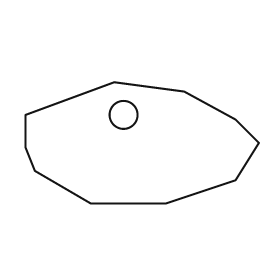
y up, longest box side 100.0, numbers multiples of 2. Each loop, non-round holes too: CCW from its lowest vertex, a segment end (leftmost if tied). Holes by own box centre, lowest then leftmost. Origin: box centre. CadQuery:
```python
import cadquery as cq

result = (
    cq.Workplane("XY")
    .moveTo(-22.0, -26.0)
    .lineTo(10.0, -26.0)
    .lineTo(40.0, -16.0)
    .lineTo(50.0, 0.0)
    .lineTo(40.0, 10.0)
    .lineTo(18.0, 22.0)
    .lineTo(-12.0, 26.0)
    .lineTo(-50.0, 12.0)
    .lineTo(-50.0, -2.0)
    .lineTo(-46.0, -12.0)
    .close()
    .moveTo(-8.0, 12.0)
    .circle(6.0)
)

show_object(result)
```